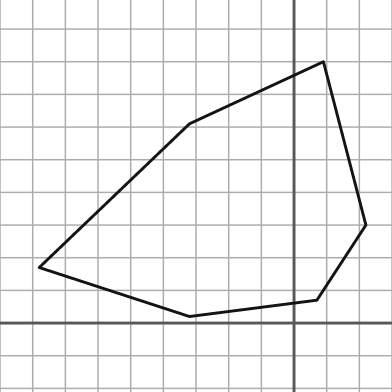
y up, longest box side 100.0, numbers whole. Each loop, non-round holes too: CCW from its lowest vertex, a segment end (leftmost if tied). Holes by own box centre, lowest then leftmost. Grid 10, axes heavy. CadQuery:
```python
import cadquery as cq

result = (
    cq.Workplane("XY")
    .moveTo(-32.0, 2.0)
    .lineTo(7.0, 7.0)
    .lineTo(22.0, 30.0)
    .lineTo(9.0, 80.0)
    .lineTo(-32.0, 61.0)
    .lineTo(-78.0, 17.0)
    .close()
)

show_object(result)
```